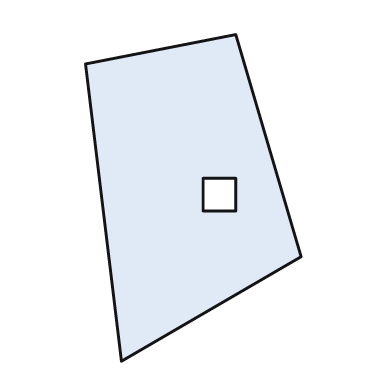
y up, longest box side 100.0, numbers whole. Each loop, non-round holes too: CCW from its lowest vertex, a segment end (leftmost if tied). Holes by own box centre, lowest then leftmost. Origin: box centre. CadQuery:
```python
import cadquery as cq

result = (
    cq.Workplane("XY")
    .moveTo(-22.0, -50.0)
    .lineTo(33.0, -18.0)
    .lineTo(13.0, 50.0)
    .lineTo(-33.0, 41.0)
    .close()
    .moveTo(3.0, -4.0)
    .lineTo(13.0, -4.0)
    .lineTo(13.0, 6.0)
    .lineTo(3.0, 6.0)
    .close()
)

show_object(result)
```